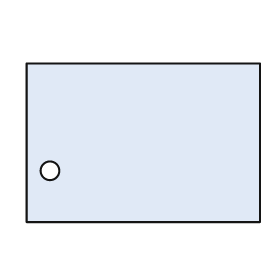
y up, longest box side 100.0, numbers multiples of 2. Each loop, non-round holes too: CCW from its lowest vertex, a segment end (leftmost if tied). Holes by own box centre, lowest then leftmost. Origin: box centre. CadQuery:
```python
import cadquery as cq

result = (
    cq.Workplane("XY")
    .moveTo(-50.0, -34.0)
    .lineTo(50.0, -34.0)
    .lineTo(50.0, 34.0)
    .lineTo(-50.0, 34.0)
    .close()
    .moveTo(-40.0, -12.0)
    .circle(4.0)
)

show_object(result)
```